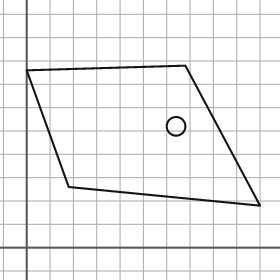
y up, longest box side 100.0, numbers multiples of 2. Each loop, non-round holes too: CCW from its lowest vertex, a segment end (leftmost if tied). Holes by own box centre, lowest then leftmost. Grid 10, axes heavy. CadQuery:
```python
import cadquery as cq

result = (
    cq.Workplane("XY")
    .moveTo(100.0, 18.0)
    .lineTo(68.0, 78.0)
    .lineTo(0.0, 76.0)
    .lineTo(18.0, 26.0)
    .close()
    .moveTo(64.0, 52.0)
    .circle(4.0)
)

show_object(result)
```